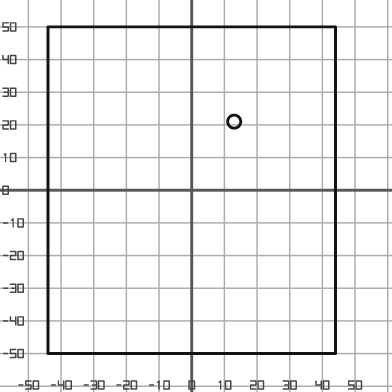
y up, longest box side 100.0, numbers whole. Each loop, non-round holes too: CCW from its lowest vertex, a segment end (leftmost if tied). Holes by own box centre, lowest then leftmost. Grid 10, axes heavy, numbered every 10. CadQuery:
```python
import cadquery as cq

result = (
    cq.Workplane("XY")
    .moveTo(-44.0, -50.0)
    .lineTo(44.0, -50.0)
    .lineTo(44.0, 50.0)
    .lineTo(-44.0, 50.0)
    .close()
    .moveTo(13.0, 21.0)
    .circle(2.0)
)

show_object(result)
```